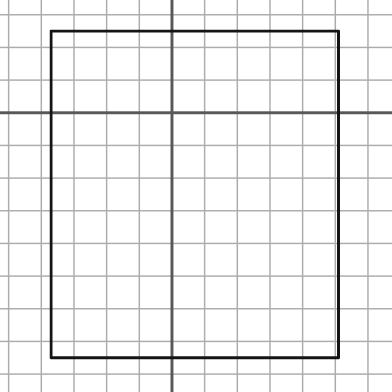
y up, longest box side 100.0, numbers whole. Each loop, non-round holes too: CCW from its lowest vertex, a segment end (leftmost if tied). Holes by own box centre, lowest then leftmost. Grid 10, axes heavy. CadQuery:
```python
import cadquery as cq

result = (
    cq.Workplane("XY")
    .moveTo(-37.0, -75.0)
    .lineTo(51.0, -75.0)
    .lineTo(51.0, 25.0)
    .lineTo(-37.0, 25.0)
    .close()
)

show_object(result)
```